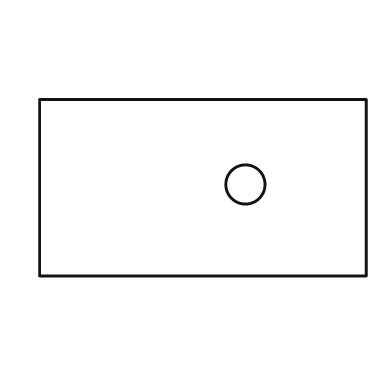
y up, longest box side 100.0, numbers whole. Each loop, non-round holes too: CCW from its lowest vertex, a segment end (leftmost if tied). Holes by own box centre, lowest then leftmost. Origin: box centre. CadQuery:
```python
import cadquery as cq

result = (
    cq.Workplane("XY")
    .moveTo(-50.0, -27.0)
    .lineTo(50.0, -27.0)
    .lineTo(50.0, 27.0)
    .lineTo(-50.0, 27.0)
    .close()
    .moveTo(13.0, 1.0)
    .circle(6.0)
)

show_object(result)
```